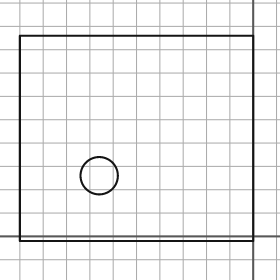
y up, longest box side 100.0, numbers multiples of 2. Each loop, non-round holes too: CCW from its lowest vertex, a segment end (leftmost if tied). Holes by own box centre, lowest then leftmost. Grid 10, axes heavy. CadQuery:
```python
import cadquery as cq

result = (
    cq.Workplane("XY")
    .moveTo(-100.0, -2.0)
    .lineTo(0.0, -2.0)
    .lineTo(0.0, 86.0)
    .lineTo(-100.0, 86.0)
    .close()
    .moveTo(-66.0, 26.0)
    .circle(8.0)
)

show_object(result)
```